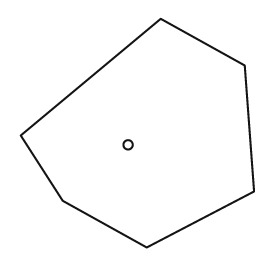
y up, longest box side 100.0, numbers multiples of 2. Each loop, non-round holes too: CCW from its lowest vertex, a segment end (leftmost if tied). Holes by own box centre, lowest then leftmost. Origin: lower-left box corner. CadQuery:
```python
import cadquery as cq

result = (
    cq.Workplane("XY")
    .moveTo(54.0, 0.0)
    .lineTo(100.0, 24.0)
    .lineTo(96.0, 78.0)
    .lineTo(60.0, 98.0)
    .lineTo(0.0, 48.0)
    .lineTo(18.0, 20.0)
    .close()
    .moveTo(46.0, 44.0)
    .circle(2.0)
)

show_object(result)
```